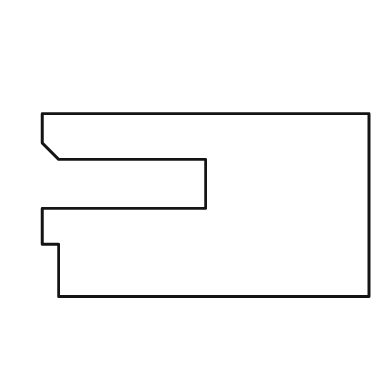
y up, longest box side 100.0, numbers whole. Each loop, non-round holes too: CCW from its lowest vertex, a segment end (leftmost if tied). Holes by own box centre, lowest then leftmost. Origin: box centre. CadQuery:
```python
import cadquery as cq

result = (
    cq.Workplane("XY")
    .moveTo(-45.0, -28.0)
    .lineTo(50.0, -28.0)
    .lineTo(50.0, 28.0)
    .lineTo(-50.0, 28.0)
    .lineTo(-50.0, 19.0)
    .lineTo(-45.0, 14.0)
    .lineTo(0.0, 14.0)
    .lineTo(0.0, -1.0)
    .lineTo(-50.0, -1.0)
    .lineTo(-50.0, -12.0)
    .lineTo(-45.0, -12.0)
    .close()
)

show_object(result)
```